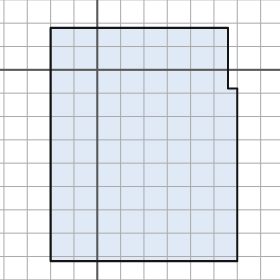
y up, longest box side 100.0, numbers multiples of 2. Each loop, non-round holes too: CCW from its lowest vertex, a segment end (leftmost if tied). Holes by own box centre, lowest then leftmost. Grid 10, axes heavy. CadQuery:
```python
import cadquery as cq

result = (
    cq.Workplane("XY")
    .moveTo(-20.0, -82.0)
    .lineTo(60.0, -82.0)
    .lineTo(60.0, -8.0)
    .lineTo(56.0, -8.0)
    .lineTo(56.0, 18.0)
    .lineTo(-20.0, 18.0)
    .close()
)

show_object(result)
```